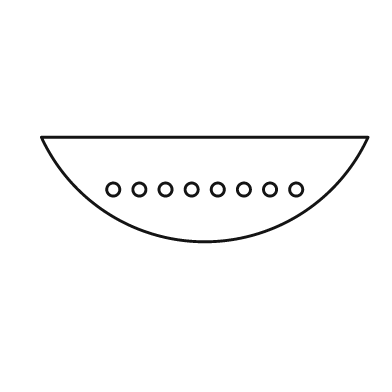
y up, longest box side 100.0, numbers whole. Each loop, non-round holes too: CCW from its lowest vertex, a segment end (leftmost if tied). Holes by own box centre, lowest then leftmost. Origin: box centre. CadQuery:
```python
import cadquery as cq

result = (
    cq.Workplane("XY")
    .moveTo(-50.0, 16.0)
    .threePointArc((0.0, -16.0), (50.0, 16.0))
    .close()
    .moveTo(-28.0, 0.0)
    .circle(2.0)
    .moveTo(-20.0, 0.0)
    .circle(2.0)
    .moveTo(-12.0, 0.0)
    .circle(2.0)
    .moveTo(-4.0, 0.0)
    .circle(2.0)
    .moveTo(4.0, 0.0)
    .circle(2.0)
    .moveTo(12.0, 0.0)
    .circle(2.0)
    .moveTo(20.0, 0.0)
    .circle(2.0)
    .moveTo(28.0, 0.0)
    .circle(2.0)
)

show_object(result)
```